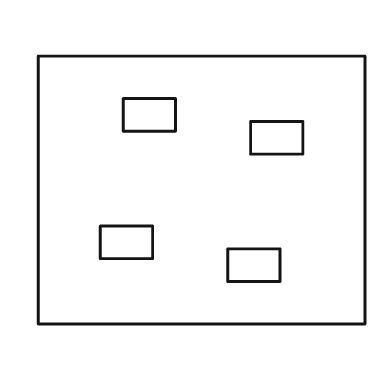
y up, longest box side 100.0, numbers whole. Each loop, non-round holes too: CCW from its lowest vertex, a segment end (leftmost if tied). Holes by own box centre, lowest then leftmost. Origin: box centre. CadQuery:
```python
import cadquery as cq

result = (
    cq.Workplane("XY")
    .moveTo(-50.0, -41.0)
    .lineTo(50.0, -41.0)
    .lineTo(50.0, 41.0)
    .lineTo(-50.0, 41.0)
    .close()
    .moveTo(8.0, -28.0)
    .lineTo(24.0, -28.0)
    .lineTo(24.0, -18.0)
    .lineTo(8.0, -18.0)
    .close()
    .moveTo(-31.0, -21.0)
    .lineTo(-15.0, -21.0)
    .lineTo(-15.0, -11.0)
    .lineTo(-31.0, -11.0)
    .close()
    .moveTo(15.0, 11.0)
    .lineTo(31.0, 11.0)
    .lineTo(31.0, 21.0)
    .lineTo(15.0, 21.0)
    .close()
    .moveTo(-24.0, 18.0)
    .lineTo(-8.0, 18.0)
    .lineTo(-8.0, 28.0)
    .lineTo(-24.0, 28.0)
    .close()
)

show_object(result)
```